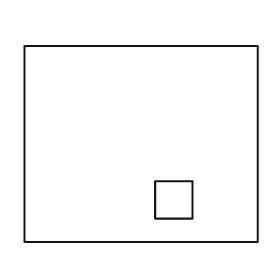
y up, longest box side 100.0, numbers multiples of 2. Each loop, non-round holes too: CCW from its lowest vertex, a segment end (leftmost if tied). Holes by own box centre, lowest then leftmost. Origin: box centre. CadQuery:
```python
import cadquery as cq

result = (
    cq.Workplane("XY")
    .moveTo(-50.0, -42.0)
    .lineTo(50.0, -42.0)
    .lineTo(50.0, 42.0)
    .lineTo(-50.0, 42.0)
    .close()
    .moveTo(6.0, -32.0)
    .lineTo(22.0, -32.0)
    .lineTo(22.0, -16.0)
    .lineTo(6.0, -16.0)
    .close()
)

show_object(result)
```